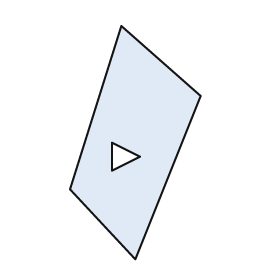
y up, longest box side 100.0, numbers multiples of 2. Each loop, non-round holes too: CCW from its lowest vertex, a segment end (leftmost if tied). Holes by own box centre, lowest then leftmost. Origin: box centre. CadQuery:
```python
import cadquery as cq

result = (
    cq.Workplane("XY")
    .moveTo(0.0, -50.0)
    .lineTo(28.0, 20.0)
    .lineTo(-6.0, 50.0)
    .lineTo(-28.0, -20.0)
    .close()
    .moveTo(-10.0, -12.0)
    .lineTo(2.0, -6.0)
    .lineTo(-10.0, 0.0)
    .close()
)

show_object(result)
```